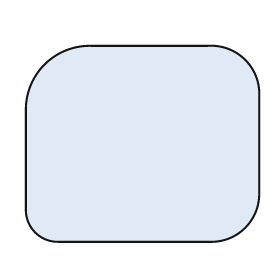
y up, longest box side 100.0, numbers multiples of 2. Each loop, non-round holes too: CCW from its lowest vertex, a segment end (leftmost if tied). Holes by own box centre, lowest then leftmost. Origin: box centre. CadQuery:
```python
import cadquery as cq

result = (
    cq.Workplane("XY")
    .moveTo(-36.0, -42.0)
    .lineTo(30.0, -42.0)
    .threePointArc((44.0, -36.0), (50.0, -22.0))
    .lineTo(50.0, 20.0)
    .threePointArc((44.0, 36.0), (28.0, 42.0))
    .lineTo(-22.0, 42.0)
    .threePointArc((-42.0, 34.0), (-50.0, 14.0))
    .lineTo(-50.0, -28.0)
    .threePointArc((-46.0, -38.0), (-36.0, -42.0))
    .close()
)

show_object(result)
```